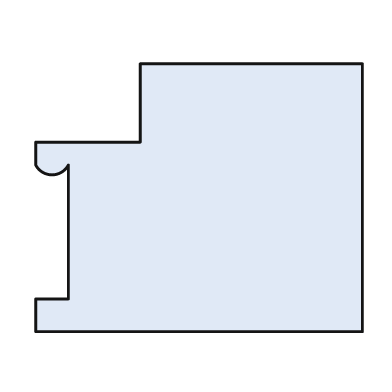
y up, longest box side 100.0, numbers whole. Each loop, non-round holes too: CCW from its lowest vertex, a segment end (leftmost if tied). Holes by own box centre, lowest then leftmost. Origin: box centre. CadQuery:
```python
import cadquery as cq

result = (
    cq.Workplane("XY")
    .moveTo(-50.0, -41.0)
    .lineTo(50.0, -41.0)
    .lineTo(50.0, 41.0)
    .lineTo(-18.0, 41.0)
    .lineTo(-18.0, 17.0)
    .lineTo(-50.0, 17.0)
    .lineTo(-50.0, 10.0)
    .threePointArc((-45.0, 7.0), (-40.0, 10.0))
    .lineTo(-40.0, -31.0)
    .lineTo(-50.0, -31.0)
    .close()
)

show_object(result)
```